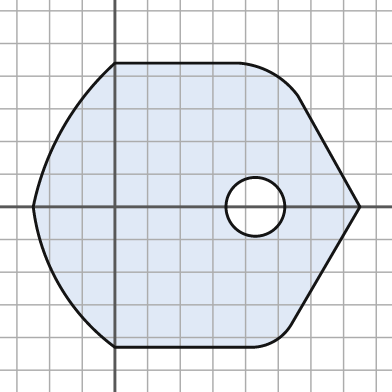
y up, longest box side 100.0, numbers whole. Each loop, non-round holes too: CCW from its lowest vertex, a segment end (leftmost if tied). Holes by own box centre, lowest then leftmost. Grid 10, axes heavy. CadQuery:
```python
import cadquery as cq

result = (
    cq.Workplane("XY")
    .moveTo(0.0, -43.0)
    .lineTo(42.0, -43.0)
    .threePointArc((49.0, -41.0), (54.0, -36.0))
    .lineTo(75.0, 0.0)
    .lineTo(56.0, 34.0)
    .threePointArc((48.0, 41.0), (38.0, 44.0))
    .lineTo(0.0, 44.0)
    .threePointArc((-16.0, 24.0), (-25.0, 0.0))
    .threePointArc((-17.0, -24.0), (0.0, -43.0))
    .close()
    .moveTo(43.0, 0.0)
    .circle(9.0)
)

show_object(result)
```